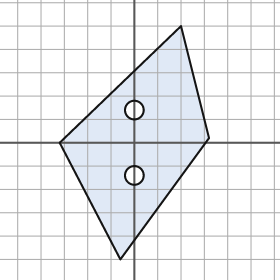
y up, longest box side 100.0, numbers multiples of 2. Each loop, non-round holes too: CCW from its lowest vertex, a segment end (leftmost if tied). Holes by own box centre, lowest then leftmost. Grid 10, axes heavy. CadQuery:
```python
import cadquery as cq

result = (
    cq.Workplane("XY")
    .moveTo(-6.0, -50.0)
    .lineTo(32.0, 2.0)
    .lineTo(20.0, 50.0)
    .lineTo(-32.0, 0.0)
    .close()
    .moveTo(0.0, -14.0)
    .circle(4.0)
    .moveTo(0.0, 14.0)
    .circle(4.0)
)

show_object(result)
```